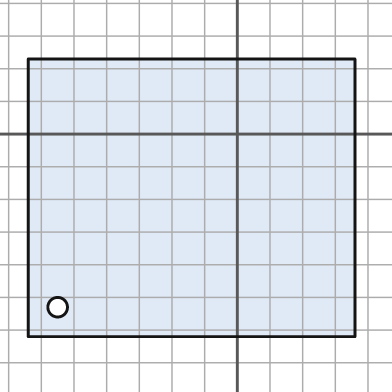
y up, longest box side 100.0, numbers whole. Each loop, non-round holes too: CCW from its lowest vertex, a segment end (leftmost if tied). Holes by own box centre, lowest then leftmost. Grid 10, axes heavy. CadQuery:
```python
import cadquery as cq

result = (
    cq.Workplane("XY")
    .moveTo(-64.0, -62.0)
    .lineTo(36.0, -62.0)
    .lineTo(36.0, 23.0)
    .lineTo(-64.0, 23.0)
    .close()
    .moveTo(-55.0, -53.0)
    .circle(3.0)
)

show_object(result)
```